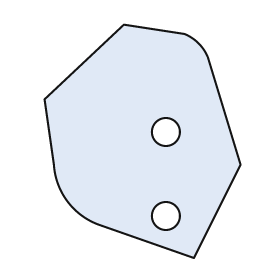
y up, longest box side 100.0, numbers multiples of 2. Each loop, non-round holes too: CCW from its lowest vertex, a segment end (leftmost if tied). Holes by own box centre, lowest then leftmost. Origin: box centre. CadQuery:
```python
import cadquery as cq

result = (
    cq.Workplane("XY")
    .moveTo(22.0, -50.0)
    .lineTo(42.0, -10.0)
    .lineTo(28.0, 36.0)
    .threePointArc((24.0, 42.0), (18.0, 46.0))
    .lineTo(-8.0, 50.0)
    .lineTo(-42.0, 18.0)
    .lineTo(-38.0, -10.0)
    .threePointArc((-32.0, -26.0), (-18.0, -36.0))
    .close()
    .moveTo(10.0, -32.0)
    .circle(6.0)
    .moveTo(10.0, 4.0)
    .circle(6.0)
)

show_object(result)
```